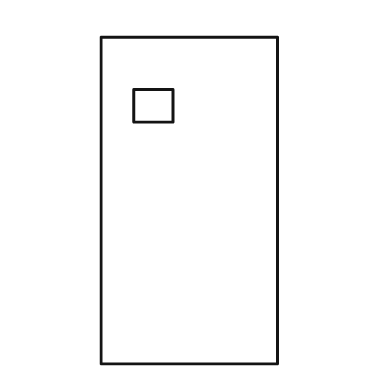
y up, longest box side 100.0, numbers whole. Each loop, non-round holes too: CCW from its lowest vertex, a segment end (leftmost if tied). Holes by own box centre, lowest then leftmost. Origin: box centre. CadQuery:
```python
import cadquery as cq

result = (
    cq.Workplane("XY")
    .moveTo(-27.0, -50.0)
    .lineTo(27.0, -50.0)
    .lineTo(27.0, 50.0)
    .lineTo(-27.0, 50.0)
    .close()
    .moveTo(-17.0, 24.0)
    .lineTo(-5.0, 24.0)
    .lineTo(-5.0, 34.0)
    .lineTo(-17.0, 34.0)
    .close()
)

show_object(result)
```